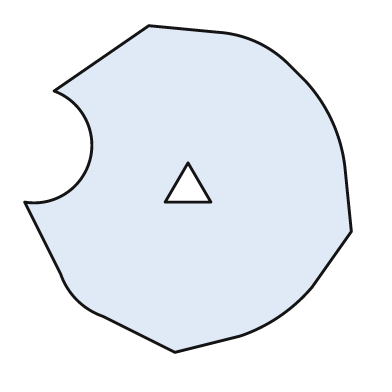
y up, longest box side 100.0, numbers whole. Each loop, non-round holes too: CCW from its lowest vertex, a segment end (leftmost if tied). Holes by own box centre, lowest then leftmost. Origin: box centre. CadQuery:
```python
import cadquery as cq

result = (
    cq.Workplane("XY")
    .moveTo(-4.0, -50.0)
    .lineTo(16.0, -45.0)
    .threePointArc((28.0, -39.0), (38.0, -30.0))
    .lineTo(50.0, -13.0)
    .lineTo(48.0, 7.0)
    .threePointArc((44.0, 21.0), (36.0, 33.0))
    .lineTo(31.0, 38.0)
    .threePointArc((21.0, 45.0), (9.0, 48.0))
    .lineTo(-12.0, 50.0)
    .lineTo(-41.0, 30.0)
    .threePointArc((-30.0, 9.0), (-50.0, -4.0))
    .lineTo(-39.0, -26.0)
    .threePointArc((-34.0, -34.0), (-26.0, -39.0))
    .close()
    .moveTo(-7.0, -4.0)
    .lineTo(7.0, -4.0)
    .lineTo(0.0, 8.0)
    .close()
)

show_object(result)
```